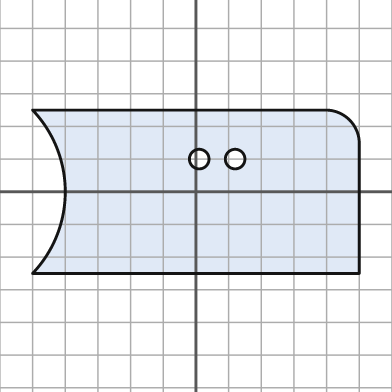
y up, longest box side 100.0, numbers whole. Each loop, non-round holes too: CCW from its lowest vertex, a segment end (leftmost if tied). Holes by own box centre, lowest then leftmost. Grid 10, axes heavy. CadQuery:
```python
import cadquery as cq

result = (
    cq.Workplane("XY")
    .moveTo(-50.0, -25.0)
    .lineTo(50.0, -25.0)
    .lineTo(50.0, 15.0)
    .threePointArc((47.0, 22.0), (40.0, 25.0))
    .lineTo(-50.0, 25.0)
    .threePointArc((-40.0, 0.0), (-50.0, -25.0))
    .close()
    .moveTo(1.0, 10.0)
    .circle(3.0)
    .moveTo(12.0, 10.0)
    .circle(3.0)
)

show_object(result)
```